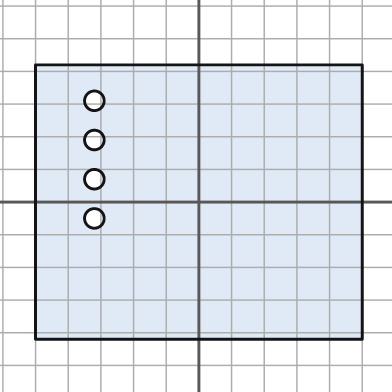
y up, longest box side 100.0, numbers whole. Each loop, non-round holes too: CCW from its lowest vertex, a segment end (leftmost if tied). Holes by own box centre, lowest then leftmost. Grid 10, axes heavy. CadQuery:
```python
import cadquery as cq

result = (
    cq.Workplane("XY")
    .moveTo(-50.0, -42.0)
    .lineTo(50.0, -42.0)
    .lineTo(50.0, 42.0)
    .lineTo(-50.0, 42.0)
    .close()
    .moveTo(-32.0, -5.0)
    .circle(3.0)
    .moveTo(-32.0, 7.0)
    .circle(3.0)
    .moveTo(-32.0, 19.0)
    .circle(3.0)
    .moveTo(-32.0, 31.0)
    .circle(3.0)
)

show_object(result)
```